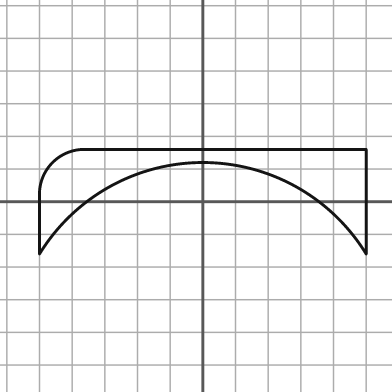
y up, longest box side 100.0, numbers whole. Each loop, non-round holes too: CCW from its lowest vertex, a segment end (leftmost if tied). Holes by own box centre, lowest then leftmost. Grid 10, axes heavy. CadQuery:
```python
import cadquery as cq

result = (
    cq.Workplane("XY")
    .moveTo(-50.0, -16.0)
    .threePointArc((0.0, 12.0), (50.0, -16.0))
    .lineTo(50.0, 16.0)
    .lineTo(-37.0, 16.0)
    .threePointArc((-46.0, 12.0), (-50.0, 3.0))
    .close()
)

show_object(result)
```